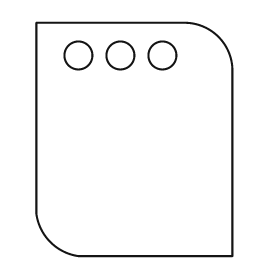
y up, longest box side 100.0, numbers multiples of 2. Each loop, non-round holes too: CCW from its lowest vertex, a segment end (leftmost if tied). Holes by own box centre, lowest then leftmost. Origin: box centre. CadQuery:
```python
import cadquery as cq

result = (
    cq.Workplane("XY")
    .moveTo(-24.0, -50.0)
    .lineTo(42.0, -50.0)
    .lineTo(42.0, 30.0)
    .threePointArc((36.0, 44.0), (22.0, 50.0))
    .lineTo(-42.0, 50.0)
    .lineTo(-42.0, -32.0)
    .threePointArc((-36.0, -44.0), (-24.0, -50.0))
    .close()
    .moveTo(-24.0, 36.0)
    .circle(6.0)
    .moveTo(-6.0, 36.0)
    .circle(6.0)
    .moveTo(12.0, 36.0)
    .circle(6.0)
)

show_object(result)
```